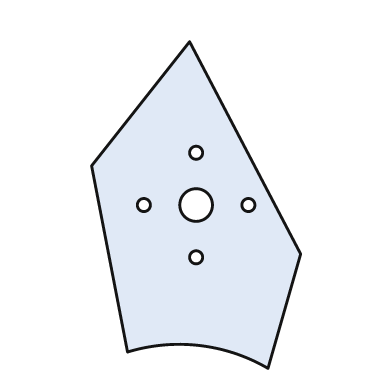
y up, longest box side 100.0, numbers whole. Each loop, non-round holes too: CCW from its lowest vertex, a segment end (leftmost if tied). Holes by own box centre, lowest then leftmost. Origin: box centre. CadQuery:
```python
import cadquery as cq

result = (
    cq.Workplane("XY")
    .moveTo(22.0, -50.0)
    .lineTo(32.0, -15.0)
    .lineTo(-2.0, 50.0)
    .lineTo(-32.0, 12.0)
    .lineTo(-21.0, -45.0)
    .threePointArc((1.0, -43.0), (22.0, -50.0))
    .close()
    .moveTo(0.0, -16.0)
    .circle(2.0)
    .moveTo(-16.0, 0.0)
    .circle(2.0)
    .moveTo(0.0, 0.0)
    .circle(5.0)
    .moveTo(16.0, 0.0)
    .circle(2.0)
    .moveTo(0.0, 16.0)
    .circle(2.0)
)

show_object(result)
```